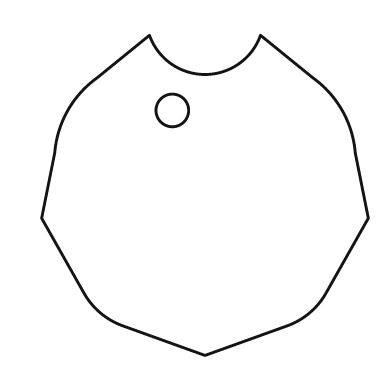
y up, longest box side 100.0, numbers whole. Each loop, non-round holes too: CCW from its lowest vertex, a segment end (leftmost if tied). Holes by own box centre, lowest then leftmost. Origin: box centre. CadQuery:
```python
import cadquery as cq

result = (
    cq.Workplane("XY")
    .moveTo(0.0, -49.0)
    .lineTo(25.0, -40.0)
    .threePointArc((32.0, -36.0), (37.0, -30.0))
    .lineTo(50.0, -7.0)
    .lineTo(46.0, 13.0)
    .threePointArc((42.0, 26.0), (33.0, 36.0))
    .lineTo(17.0, 49.0)
    .threePointArc((0.0, 37.0), (-17.0, 49.0))
    .lineTo(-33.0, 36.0)
    .threePointArc((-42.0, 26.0), (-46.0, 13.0))
    .lineTo(-50.0, -7.0)
    .lineTo(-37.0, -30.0)
    .threePointArc((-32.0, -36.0), (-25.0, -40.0))
    .close()
    .moveTo(-10.0, 26.0)
    .circle(5.0)
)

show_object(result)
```